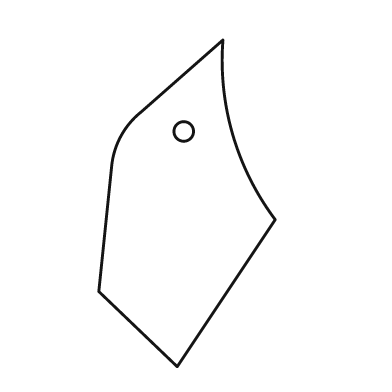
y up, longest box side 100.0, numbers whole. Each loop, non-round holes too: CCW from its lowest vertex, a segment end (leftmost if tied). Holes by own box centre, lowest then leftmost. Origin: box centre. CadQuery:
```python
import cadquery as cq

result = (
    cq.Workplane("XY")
    .moveTo(-3.0, -50.0)
    .lineTo(27.0, -5.0)
    .threePointArc((14.0, 21.0), (11.0, 50.0))
    .lineTo(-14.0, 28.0)
    .threePointArc((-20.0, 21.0), (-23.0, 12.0))
    .lineTo(-27.0, -27.0)
    .close()
    .moveTo(-1.0, 22.0)
    .circle(3.0)
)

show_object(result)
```